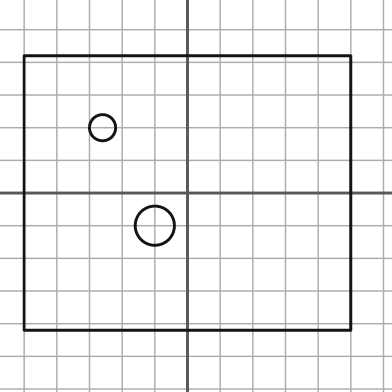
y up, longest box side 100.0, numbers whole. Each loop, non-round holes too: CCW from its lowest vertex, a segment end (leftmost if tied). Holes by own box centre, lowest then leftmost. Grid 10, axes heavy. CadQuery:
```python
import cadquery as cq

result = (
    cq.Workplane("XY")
    .moveTo(-50.0, -42.0)
    .lineTo(50.0, -42.0)
    .lineTo(50.0, 42.0)
    .lineTo(-50.0, 42.0)
    .close()
    .moveTo(-10.0, -10.0)
    .circle(6.0)
    .moveTo(-26.0, 20.0)
    .circle(4.0)
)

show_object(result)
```